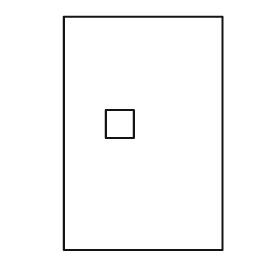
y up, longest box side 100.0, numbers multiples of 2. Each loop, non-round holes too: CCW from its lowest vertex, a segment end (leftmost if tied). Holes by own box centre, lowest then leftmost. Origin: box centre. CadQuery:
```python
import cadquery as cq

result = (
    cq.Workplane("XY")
    .moveTo(-34.0, -50.0)
    .lineTo(34.0, -50.0)
    .lineTo(34.0, 50.0)
    .lineTo(-34.0, 50.0)
    .close()
    .moveTo(-16.0, -2.0)
    .lineTo(-4.0, -2.0)
    .lineTo(-4.0, 10.0)
    .lineTo(-16.0, 10.0)
    .close()
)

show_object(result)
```